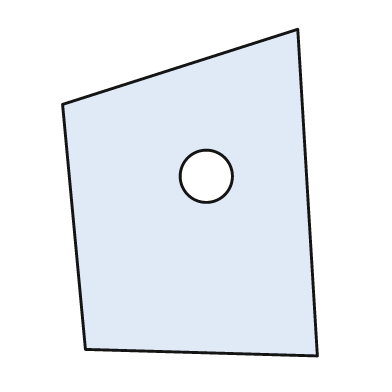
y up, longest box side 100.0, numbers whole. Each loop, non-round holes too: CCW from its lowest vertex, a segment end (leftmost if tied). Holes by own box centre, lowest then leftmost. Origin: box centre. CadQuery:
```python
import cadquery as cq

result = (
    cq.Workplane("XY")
    .moveTo(39.0, -50.0)
    .lineTo(33.0, 50.0)
    .lineTo(-39.0, 27.0)
    .lineTo(-32.0, -48.0)
    .close()
    .moveTo(5.0, 5.0)
    .circle(8.0)
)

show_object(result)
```